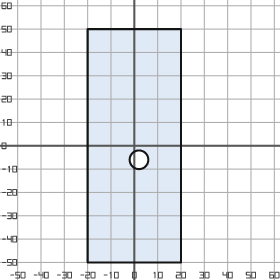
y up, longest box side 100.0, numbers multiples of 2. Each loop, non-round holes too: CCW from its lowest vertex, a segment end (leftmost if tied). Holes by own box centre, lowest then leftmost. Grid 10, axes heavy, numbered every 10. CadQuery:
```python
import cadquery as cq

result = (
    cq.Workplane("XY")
    .moveTo(-20.0, -50.0)
    .lineTo(20.0, -50.0)
    .lineTo(20.0, 50.0)
    .lineTo(-20.0, 50.0)
    .close()
    .moveTo(2.0, -6.0)
    .circle(4.0)
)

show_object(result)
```